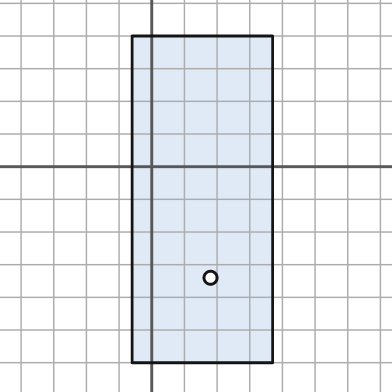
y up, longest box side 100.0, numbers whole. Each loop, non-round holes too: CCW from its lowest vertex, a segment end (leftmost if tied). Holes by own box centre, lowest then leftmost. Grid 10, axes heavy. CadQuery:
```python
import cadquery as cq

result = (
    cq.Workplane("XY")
    .moveTo(-6.0, -60.0)
    .lineTo(37.0, -60.0)
    .lineTo(37.0, 40.0)
    .lineTo(-6.0, 40.0)
    .close()
    .moveTo(18.0, -34.0)
    .circle(2.0)
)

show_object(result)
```